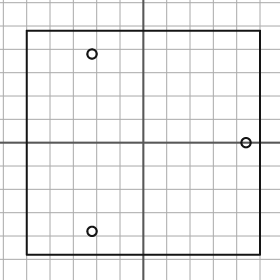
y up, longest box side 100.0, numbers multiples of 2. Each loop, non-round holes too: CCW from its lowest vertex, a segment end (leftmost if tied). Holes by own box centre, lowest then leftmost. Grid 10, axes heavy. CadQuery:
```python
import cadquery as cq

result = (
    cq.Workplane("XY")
    .moveTo(-50.0, -48.0)
    .lineTo(50.0, -48.0)
    .lineTo(50.0, 48.0)
    .lineTo(-50.0, 48.0)
    .close()
    .moveTo(-22.0, -38.0)
    .circle(2.0)
    .moveTo(44.0, 0.0)
    .circle(2.0)
    .moveTo(-22.0, 38.0)
    .circle(2.0)
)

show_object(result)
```